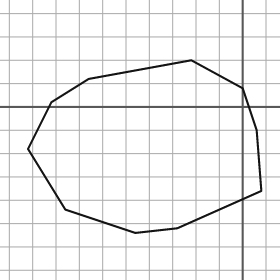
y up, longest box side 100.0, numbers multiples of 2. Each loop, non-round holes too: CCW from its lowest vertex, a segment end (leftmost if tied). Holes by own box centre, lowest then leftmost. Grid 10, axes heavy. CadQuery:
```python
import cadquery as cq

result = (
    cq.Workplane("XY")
    .moveTo(-46.0, -54.0)
    .lineTo(-28.0, -52.0)
    .lineTo(8.0, -36.0)
    .lineTo(6.0, -10.0)
    .lineTo(0.0, 8.0)
    .lineTo(-22.0, 20.0)
    .lineTo(-66.0, 12.0)
    .lineTo(-82.0, 2.0)
    .lineTo(-92.0, -18.0)
    .lineTo(-76.0, -44.0)
    .close()
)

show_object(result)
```